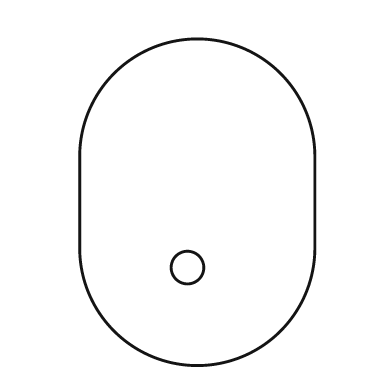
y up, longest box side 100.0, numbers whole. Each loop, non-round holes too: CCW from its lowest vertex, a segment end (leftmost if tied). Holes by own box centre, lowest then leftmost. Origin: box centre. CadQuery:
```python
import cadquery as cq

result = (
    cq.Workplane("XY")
    .moveTo(-36.0, -14.0)
    .threePointArc((0.0, -50.0), (36.0, -14.0))
    .lineTo(36.0, 14.0)
    .threePointArc((0.0, 50.0), (-36.0, 14.0))
    .close()
    .moveTo(-3.0, -20.0)
    .circle(5.0)
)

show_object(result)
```